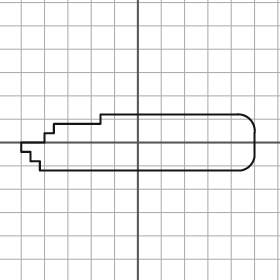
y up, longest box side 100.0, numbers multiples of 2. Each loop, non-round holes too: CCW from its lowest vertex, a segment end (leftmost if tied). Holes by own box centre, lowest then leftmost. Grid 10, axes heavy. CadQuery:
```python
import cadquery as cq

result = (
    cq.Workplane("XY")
    .moveTo(-42.0, -12.0)
    .lineTo(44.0, -12.0)
    .threePointArc((48.0, -10.0), (50.0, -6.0))
    .lineTo(50.0, 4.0)
    .threePointArc((48.0, 10.0), (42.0, 12.0))
    .lineTo(-16.0, 12.0)
    .lineTo(-16.0, 8.0)
    .lineTo(-36.0, 8.0)
    .lineTo(-36.0, 4.0)
    .lineTo(-40.0, 4.0)
    .lineTo(-40.0, 0.0)
    .lineTo(-50.0, 0.0)
    .lineTo(-50.0, -4.0)
    .lineTo(-46.0, -4.0)
    .lineTo(-46.0, -8.0)
    .lineTo(-42.0, -8.0)
    .close()
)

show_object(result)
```